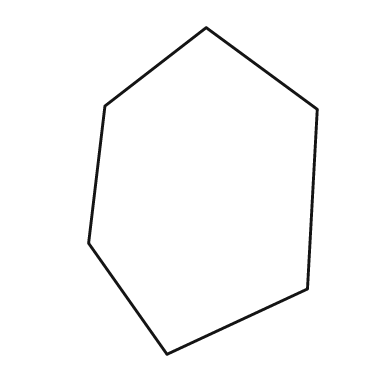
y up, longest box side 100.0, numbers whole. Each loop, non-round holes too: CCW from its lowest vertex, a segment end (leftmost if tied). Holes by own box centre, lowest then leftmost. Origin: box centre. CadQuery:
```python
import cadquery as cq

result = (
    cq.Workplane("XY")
    .moveTo(-11.0, -50.0)
    .lineTo(32.0, -30.0)
    .lineTo(35.0, 25.0)
    .lineTo(1.0, 50.0)
    .lineTo(-30.0, 26.0)
    .lineTo(-35.0, -16.0)
    .close()
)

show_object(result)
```